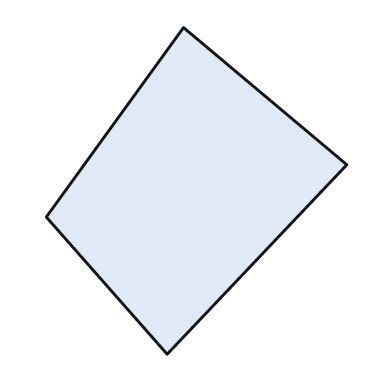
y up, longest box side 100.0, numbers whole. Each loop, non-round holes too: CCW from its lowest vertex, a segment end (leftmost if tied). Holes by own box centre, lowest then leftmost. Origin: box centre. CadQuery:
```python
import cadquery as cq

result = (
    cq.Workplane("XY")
    .moveTo(-9.0, -50.0)
    .lineTo(46.0, 8.0)
    .lineTo(-4.0, 50.0)
    .lineTo(-46.0, -8.0)
    .close()
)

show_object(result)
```